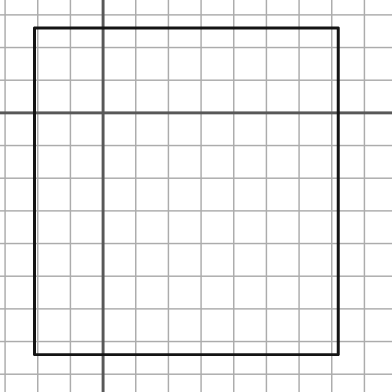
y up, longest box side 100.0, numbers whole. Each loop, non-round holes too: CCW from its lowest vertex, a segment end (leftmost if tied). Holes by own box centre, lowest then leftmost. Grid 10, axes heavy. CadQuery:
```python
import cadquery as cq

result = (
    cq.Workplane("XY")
    .moveTo(-21.0, -74.0)
    .lineTo(72.0, -74.0)
    .lineTo(72.0, 26.0)
    .lineTo(-21.0, 26.0)
    .close()
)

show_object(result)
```